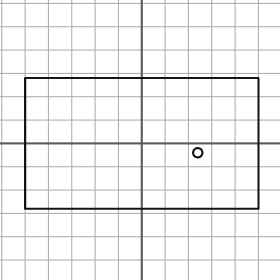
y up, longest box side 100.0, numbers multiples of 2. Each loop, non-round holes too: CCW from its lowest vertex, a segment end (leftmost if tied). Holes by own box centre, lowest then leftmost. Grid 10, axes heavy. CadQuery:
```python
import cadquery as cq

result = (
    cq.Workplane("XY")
    .moveTo(-50.0, -28.0)
    .lineTo(50.0, -28.0)
    .lineTo(50.0, 28.0)
    .lineTo(-50.0, 28.0)
    .close()
    .moveTo(24.0, -4.0)
    .circle(2.0)
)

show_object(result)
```